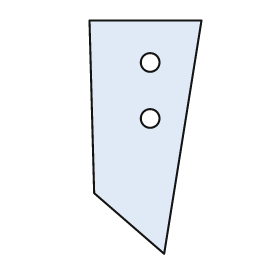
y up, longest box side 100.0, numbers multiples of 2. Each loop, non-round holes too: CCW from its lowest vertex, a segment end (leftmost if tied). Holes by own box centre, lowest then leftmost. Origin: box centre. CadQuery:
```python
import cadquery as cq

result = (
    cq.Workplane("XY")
    .moveTo(8.0, -50.0)
    .lineTo(24.0, 50.0)
    .lineTo(-24.0, 50.0)
    .lineTo(-22.0, -24.0)
    .close()
    .moveTo(2.0, 8.0)
    .circle(4.0)
    .moveTo(2.0, 32.0)
    .circle(4.0)
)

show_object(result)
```